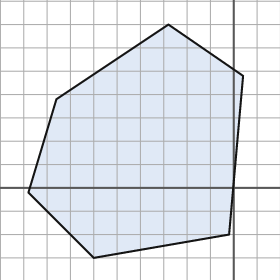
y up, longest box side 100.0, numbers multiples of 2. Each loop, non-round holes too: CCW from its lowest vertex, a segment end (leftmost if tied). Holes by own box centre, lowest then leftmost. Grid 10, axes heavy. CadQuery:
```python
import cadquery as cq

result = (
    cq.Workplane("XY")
    .moveTo(-60.0, -30.0)
    .lineTo(-2.0, -20.0)
    .lineTo(4.0, 48.0)
    .lineTo(-28.0, 70.0)
    .lineTo(-76.0, 38.0)
    .lineTo(-88.0, -2.0)
    .close()
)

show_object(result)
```